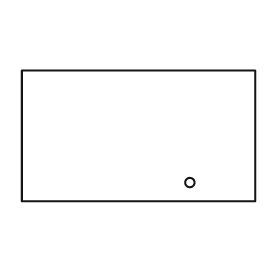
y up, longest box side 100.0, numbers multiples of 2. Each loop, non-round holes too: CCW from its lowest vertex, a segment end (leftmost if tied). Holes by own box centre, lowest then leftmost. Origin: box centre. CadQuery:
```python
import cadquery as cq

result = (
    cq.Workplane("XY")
    .moveTo(-50.0, -28.0)
    .lineTo(50.0, -28.0)
    .lineTo(50.0, 28.0)
    .lineTo(-50.0, 28.0)
    .close()
    .moveTo(22.0, -20.0)
    .circle(2.0)
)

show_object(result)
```